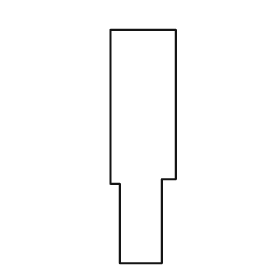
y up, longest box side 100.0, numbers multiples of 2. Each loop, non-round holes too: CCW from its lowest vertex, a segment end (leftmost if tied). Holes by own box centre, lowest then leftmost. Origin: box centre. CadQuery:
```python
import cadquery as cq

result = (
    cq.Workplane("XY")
    .moveTo(-10.0, -50.0)
    .lineTo(8.0, -50.0)
    .lineTo(8.0, -14.0)
    .lineTo(14.0, -14.0)
    .lineTo(14.0, 50.0)
    .lineTo(-14.0, 50.0)
    .lineTo(-14.0, -16.0)
    .lineTo(-10.0, -16.0)
    .close()
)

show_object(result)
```